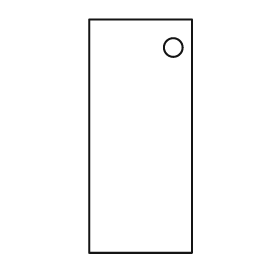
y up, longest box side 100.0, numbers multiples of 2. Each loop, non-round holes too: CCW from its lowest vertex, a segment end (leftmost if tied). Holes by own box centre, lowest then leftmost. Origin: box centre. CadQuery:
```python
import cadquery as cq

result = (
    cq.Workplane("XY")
    .moveTo(-22.0, -50.0)
    .lineTo(22.0, -50.0)
    .lineTo(22.0, 50.0)
    .lineTo(-22.0, 50.0)
    .close()
    .moveTo(14.0, 38.0)
    .circle(4.0)
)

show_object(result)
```